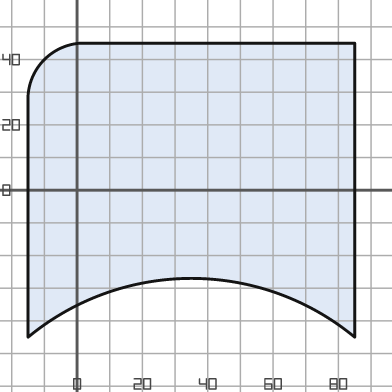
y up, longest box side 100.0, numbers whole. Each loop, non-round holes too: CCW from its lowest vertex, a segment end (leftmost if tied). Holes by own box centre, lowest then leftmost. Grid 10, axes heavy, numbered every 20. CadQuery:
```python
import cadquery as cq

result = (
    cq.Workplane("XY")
    .moveTo(-15.0, -45.0)
    .threePointArc((35.0, -27.0), (85.0, -45.0))
    .lineTo(85.0, 45.0)
    .lineTo(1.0, 45.0)
    .threePointArc((-10.0, 40.0), (-15.0, 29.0))
    .close()
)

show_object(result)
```